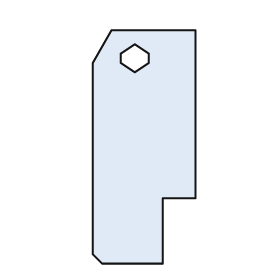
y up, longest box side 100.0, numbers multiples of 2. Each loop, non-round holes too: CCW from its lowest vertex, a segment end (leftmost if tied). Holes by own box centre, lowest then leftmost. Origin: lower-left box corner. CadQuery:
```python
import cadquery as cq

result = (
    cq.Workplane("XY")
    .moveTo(4.0, 0.0)
    .lineTo(30.0, 0.0)
    .lineTo(30.0, 28.0)
    .lineTo(44.0, 28.0)
    .lineTo(44.0, 100.0)
    .lineTo(8.0, 100.0)
    .lineTo(0.0, 86.0)
    .lineTo(0.0, 4.0)
    .close()
    .moveTo(18.0, 82.0)
    .lineTo(24.0, 86.0)
    .lineTo(24.0, 90.0)
    .lineTo(18.0, 94.0)
    .lineTo(12.0, 90.0)
    .lineTo(12.0, 86.0)
    .close()
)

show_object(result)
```